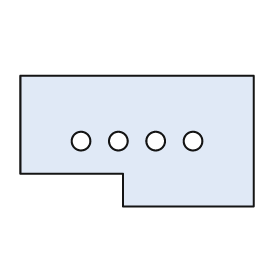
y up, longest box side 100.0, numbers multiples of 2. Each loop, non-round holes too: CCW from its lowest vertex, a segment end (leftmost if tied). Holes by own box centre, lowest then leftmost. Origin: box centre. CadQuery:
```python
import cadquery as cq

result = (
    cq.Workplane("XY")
    .moveTo(-6.0, -28.0)
    .lineTo(50.0, -28.0)
    .lineTo(50.0, 28.0)
    .lineTo(-50.0, 28.0)
    .lineTo(-50.0, -14.0)
    .lineTo(-6.0, -14.0)
    .close()
    .moveTo(-24.0, 0.0)
    .circle(4.0)
    .moveTo(-8.0, 0.0)
    .circle(4.0)
    .moveTo(8.0, 0.0)
    .circle(4.0)
    .moveTo(24.0, 0.0)
    .circle(4.0)
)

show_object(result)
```